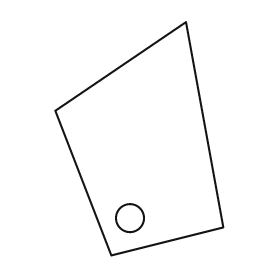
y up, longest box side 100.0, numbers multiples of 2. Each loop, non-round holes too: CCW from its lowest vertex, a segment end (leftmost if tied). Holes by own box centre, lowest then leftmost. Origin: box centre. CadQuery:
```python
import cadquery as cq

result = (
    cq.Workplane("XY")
    .moveTo(-12.0, -50.0)
    .lineTo(36.0, -38.0)
    .lineTo(20.0, 50.0)
    .lineTo(-36.0, 12.0)
    .close()
    .moveTo(-4.0, -34.0)
    .circle(6.0)
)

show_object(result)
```